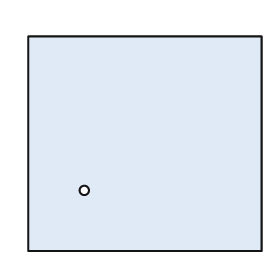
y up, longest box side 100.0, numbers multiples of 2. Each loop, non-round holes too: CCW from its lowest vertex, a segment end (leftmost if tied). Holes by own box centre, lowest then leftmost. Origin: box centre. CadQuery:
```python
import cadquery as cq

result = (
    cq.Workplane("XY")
    .moveTo(-50.0, -46.0)
    .lineTo(50.0, -46.0)
    .lineTo(50.0, 46.0)
    .lineTo(-50.0, 46.0)
    .close()
    .moveTo(-26.0, -20.0)
    .circle(2.0)
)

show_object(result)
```